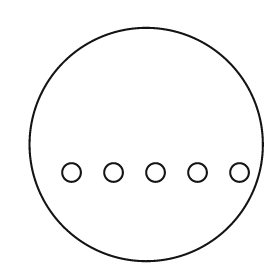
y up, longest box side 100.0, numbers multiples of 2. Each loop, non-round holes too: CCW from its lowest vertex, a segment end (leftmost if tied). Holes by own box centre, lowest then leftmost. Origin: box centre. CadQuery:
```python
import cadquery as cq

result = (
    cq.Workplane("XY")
    .moveTo(0.0, 0.0)
    .circle(50.0)
    .moveTo(-32.0, -12.0)
    .circle(4.0)
    .moveTo(-14.0, -12.0)
    .circle(4.0)
    .moveTo(4.0, -12.0)
    .circle(4.0)
    .moveTo(22.0, -12.0)
    .circle(4.0)
    .moveTo(40.0, -12.0)
    .circle(4.0)
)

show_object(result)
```